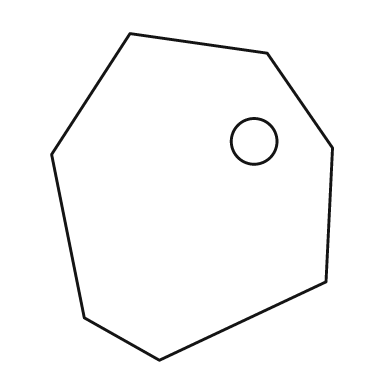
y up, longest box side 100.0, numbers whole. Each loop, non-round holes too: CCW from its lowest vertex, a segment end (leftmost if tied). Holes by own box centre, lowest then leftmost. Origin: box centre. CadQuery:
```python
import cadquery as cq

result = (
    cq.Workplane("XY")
    .moveTo(-10.0, -50.0)
    .lineTo(41.0, -26.0)
    .lineTo(43.0, 15.0)
    .lineTo(23.0, 44.0)
    .lineTo(-19.0, 50.0)
    .lineTo(-43.0, 13.0)
    .lineTo(-33.0, -37.0)
    .close()
    .moveTo(19.0, 17.0)
    .circle(7.0)
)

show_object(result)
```